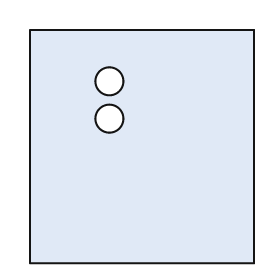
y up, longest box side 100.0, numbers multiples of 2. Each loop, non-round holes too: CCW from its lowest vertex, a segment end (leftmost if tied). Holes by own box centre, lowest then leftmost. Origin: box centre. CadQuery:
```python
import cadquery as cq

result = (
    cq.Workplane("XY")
    .moveTo(-48.0, -50.0)
    .lineTo(48.0, -50.0)
    .lineTo(48.0, 50.0)
    .lineTo(-48.0, 50.0)
    .close()
    .moveTo(-14.0, 12.0)
    .circle(6.0)
    .moveTo(-14.0, 28.0)
    .circle(6.0)
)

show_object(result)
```